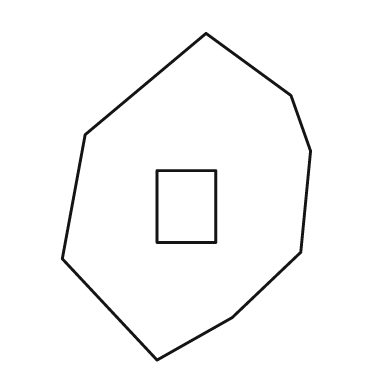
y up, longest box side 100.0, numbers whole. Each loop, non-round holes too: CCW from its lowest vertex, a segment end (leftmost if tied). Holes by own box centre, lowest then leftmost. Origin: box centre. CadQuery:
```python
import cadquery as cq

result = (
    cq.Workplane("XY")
    .moveTo(-9.0, -50.0)
    .lineTo(14.0, -37.0)
    .lineTo(35.0, -17.0)
    .lineTo(38.0, 14.0)
    .lineTo(32.0, 31.0)
    .lineTo(6.0, 50.0)
    .lineTo(-31.0, 19.0)
    .lineTo(-38.0, -19.0)
    .close()
    .moveTo(-9.0, -14.0)
    .lineTo(9.0, -14.0)
    .lineTo(9.0, 8.0)
    .lineTo(-9.0, 8.0)
    .close()
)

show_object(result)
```